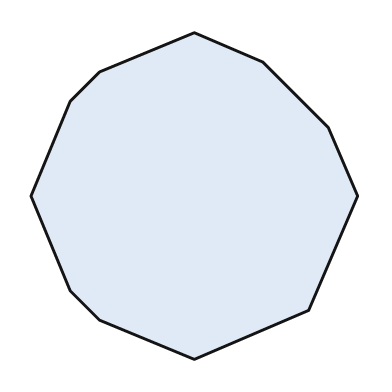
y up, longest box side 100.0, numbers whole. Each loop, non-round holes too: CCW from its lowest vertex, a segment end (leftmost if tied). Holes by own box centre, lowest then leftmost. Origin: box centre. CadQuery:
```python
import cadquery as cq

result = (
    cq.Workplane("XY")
    .moveTo(0.0, -50.0)
    .lineTo(35.0, -35.0)
    .lineTo(50.0, 0.0)
    .lineTo(41.0, 21.0)
    .lineTo(21.0, 41.0)
    .lineTo(0.0, 50.0)
    .lineTo(-29.0, 38.0)
    .lineTo(-38.0, 29.0)
    .lineTo(-50.0, 0.0)
    .lineTo(-38.0, -29.0)
    .lineTo(-29.0, -38.0)
    .close()
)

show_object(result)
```